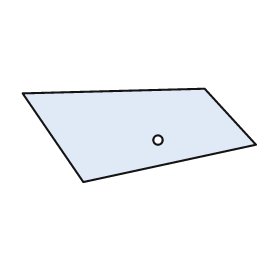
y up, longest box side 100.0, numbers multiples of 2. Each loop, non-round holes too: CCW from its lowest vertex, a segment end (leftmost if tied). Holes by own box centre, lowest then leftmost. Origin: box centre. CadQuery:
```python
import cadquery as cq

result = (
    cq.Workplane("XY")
    .moveTo(-24.0, -20.0)
    .lineTo(50.0, -4.0)
    .lineTo(28.0, 20.0)
    .lineTo(-50.0, 18.0)
    .close()
    .moveTo(8.0, -2.0)
    .circle(2.0)
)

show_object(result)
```